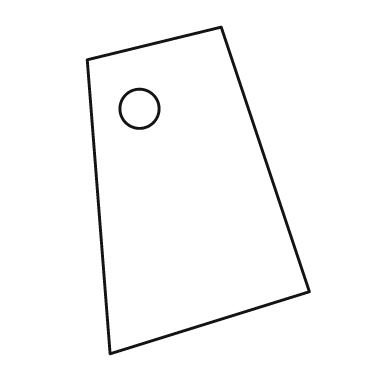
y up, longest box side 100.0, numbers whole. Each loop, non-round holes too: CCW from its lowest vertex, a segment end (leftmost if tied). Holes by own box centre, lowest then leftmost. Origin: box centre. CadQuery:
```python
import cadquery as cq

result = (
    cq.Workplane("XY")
    .moveTo(-27.0, -50.0)
    .lineTo(34.0, -31.0)
    .lineTo(7.0, 50.0)
    .lineTo(-34.0, 40.0)
    .close()
    .moveTo(-18.0, 25.0)
    .circle(6.0)
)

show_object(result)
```